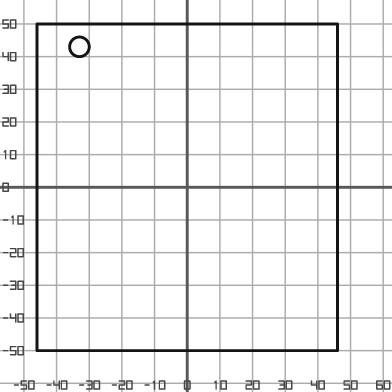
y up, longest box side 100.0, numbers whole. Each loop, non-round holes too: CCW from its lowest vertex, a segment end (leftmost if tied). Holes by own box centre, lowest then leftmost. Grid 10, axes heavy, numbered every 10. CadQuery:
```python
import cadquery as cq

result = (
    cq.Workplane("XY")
    .moveTo(-46.0, -50.0)
    .lineTo(46.0, -50.0)
    .lineTo(46.0, 50.0)
    .lineTo(-46.0, 50.0)
    .close()
    .moveTo(-33.0, 43.0)
    .circle(3.0)
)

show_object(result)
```